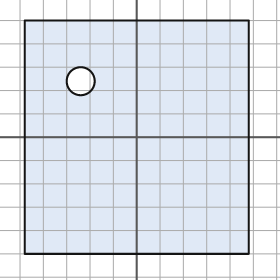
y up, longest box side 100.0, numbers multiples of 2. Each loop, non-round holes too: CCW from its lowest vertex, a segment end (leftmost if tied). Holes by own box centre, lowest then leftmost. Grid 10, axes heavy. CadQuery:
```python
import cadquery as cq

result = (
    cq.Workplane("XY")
    .moveTo(-48.0, -50.0)
    .lineTo(48.0, -50.0)
    .lineTo(48.0, 50.0)
    .lineTo(-48.0, 50.0)
    .close()
    .moveTo(-24.0, 24.0)
    .circle(6.0)
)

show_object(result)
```